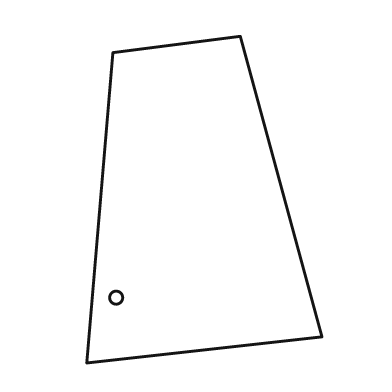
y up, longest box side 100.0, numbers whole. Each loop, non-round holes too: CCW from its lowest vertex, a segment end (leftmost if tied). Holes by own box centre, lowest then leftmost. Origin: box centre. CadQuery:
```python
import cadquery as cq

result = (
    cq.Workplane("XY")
    .moveTo(-36.0, -50.0)
    .lineTo(36.0, -42.0)
    .lineTo(11.0, 50.0)
    .lineTo(-28.0, 45.0)
    .close()
    .moveTo(-27.0, -30.0)
    .circle(2.0)
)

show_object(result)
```